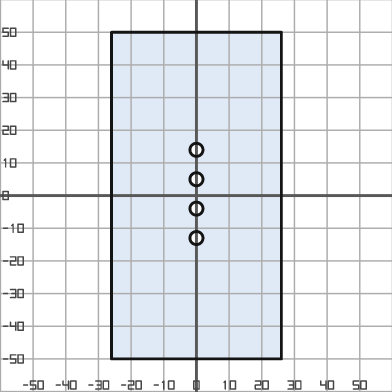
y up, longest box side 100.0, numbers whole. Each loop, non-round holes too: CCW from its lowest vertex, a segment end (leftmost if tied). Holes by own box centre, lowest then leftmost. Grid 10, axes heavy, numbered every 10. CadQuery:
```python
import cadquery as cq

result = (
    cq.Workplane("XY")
    .moveTo(-26.0, -50.0)
    .lineTo(26.0, -50.0)
    .lineTo(26.0, 50.0)
    .lineTo(-26.0, 50.0)
    .close()
    .moveTo(0.0, -13.0)
    .circle(2.0)
    .moveTo(0.0, -4.0)
    .circle(2.0)
    .moveTo(0.0, 5.0)
    .circle(2.0)
    .moveTo(0.0, 14.0)
    .circle(2.0)
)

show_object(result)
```